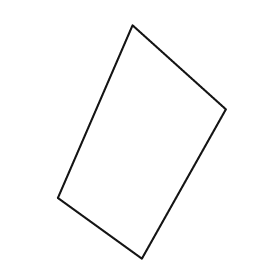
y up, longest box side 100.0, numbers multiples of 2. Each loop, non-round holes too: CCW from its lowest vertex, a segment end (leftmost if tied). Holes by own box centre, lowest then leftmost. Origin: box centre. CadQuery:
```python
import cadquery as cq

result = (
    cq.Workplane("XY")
    .moveTo(0.0, -50.0)
    .lineTo(36.0, 14.0)
    .lineTo(-4.0, 50.0)
    .lineTo(-36.0, -24.0)
    .close()
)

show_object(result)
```